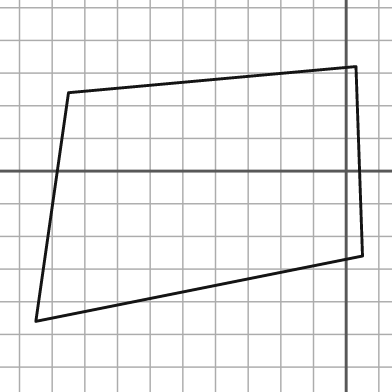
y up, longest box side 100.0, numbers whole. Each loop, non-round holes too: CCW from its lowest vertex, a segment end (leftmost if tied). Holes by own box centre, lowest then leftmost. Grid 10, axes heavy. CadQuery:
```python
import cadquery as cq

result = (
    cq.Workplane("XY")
    .moveTo(-95.0, -46.0)
    .lineTo(5.0, -26.0)
    .lineTo(3.0, 32.0)
    .lineTo(-85.0, 24.0)
    .close()
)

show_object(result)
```